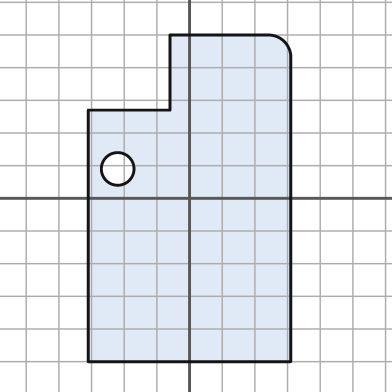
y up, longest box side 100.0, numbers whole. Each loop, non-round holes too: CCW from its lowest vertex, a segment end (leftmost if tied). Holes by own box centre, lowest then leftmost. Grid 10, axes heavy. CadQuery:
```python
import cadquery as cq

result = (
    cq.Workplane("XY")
    .moveTo(-31.0, -50.0)
    .lineTo(31.0, -50.0)
    .lineTo(31.0, 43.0)
    .threePointArc((29.0, 48.0), (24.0, 50.0))
    .lineTo(-6.0, 50.0)
    .lineTo(-6.0, 27.0)
    .lineTo(-31.0, 27.0)
    .close()
    .moveTo(-22.0, 9.0)
    .circle(5.0)
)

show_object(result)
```